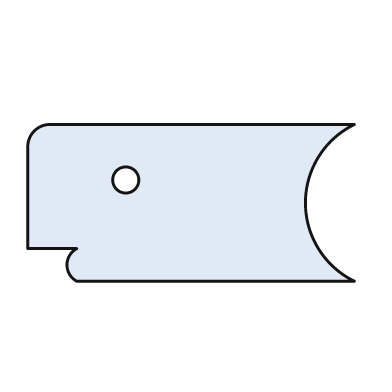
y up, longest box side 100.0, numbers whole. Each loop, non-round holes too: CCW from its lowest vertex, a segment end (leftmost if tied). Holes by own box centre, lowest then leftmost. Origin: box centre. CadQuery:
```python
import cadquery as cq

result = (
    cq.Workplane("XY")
    .moveTo(-35.0, -24.0)
    .lineTo(50.0, -24.0)
    .threePointArc((35.0, 0.0), (50.0, 24.0))
    .lineTo(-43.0, 24.0)
    .threePointArc((-48.0, 22.0), (-50.0, 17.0))
    .lineTo(-50.0, -14.0)
    .lineTo(-35.0, -14.0)
    .threePointArc((-38.0, -19.0), (-35.0, -24.0))
    .close()
    .moveTo(-20.0, 7.0)
    .circle(4.0)
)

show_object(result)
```